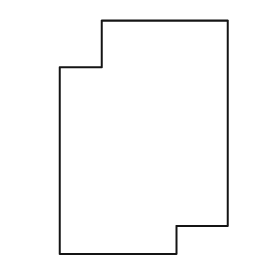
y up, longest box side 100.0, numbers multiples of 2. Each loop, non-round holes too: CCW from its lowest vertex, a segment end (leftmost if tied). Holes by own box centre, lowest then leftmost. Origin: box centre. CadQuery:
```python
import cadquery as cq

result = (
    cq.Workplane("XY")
    .moveTo(-36.0, -50.0)
    .lineTo(14.0, -50.0)
    .lineTo(14.0, -38.0)
    .lineTo(36.0, -38.0)
    .lineTo(36.0, 50.0)
    .lineTo(-18.0, 50.0)
    .lineTo(-18.0, 30.0)
    .lineTo(-36.0, 30.0)
    .close()
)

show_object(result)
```